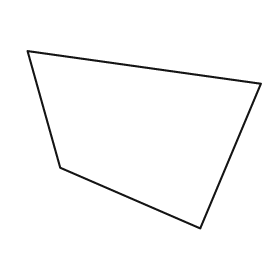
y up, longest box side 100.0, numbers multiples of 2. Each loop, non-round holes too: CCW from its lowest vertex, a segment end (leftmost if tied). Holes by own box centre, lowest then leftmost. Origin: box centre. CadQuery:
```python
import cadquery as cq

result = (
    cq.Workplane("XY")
    .moveTo(24.0, -38.0)
    .lineTo(50.0, 24.0)
    .lineTo(-50.0, 38.0)
    .lineTo(-36.0, -12.0)
    .close()
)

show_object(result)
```